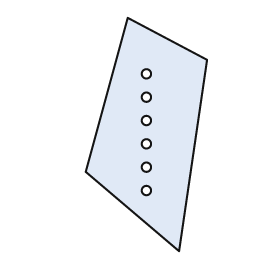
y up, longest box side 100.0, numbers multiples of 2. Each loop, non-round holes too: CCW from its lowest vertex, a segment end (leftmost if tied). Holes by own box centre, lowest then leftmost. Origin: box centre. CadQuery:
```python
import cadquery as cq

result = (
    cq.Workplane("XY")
    .moveTo(14.0, -50.0)
    .lineTo(26.0, 32.0)
    .lineTo(-8.0, 50.0)
    .lineTo(-26.0, -16.0)
    .close()
    .moveTo(0.0, -24.0)
    .circle(2.0)
    .moveTo(0.0, -14.0)
    .circle(2.0)
    .moveTo(0.0, -4.0)
    .circle(2.0)
    .moveTo(0.0, 6.0)
    .circle(2.0)
    .moveTo(0.0, 16.0)
    .circle(2.0)
    .moveTo(0.0, 26.0)
    .circle(2.0)
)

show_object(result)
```